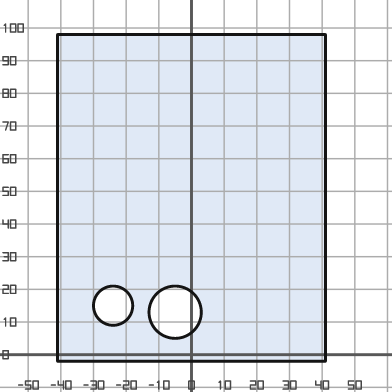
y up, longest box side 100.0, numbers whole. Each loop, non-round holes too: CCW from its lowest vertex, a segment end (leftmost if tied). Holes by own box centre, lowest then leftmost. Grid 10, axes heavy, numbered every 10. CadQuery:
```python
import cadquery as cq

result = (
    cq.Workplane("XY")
    .moveTo(-41.0, -2.0)
    .lineTo(41.0, -2.0)
    .lineTo(41.0, 98.0)
    .lineTo(-41.0, 98.0)
    .close()
    .moveTo(-5.0, 13.0)
    .circle(8.0)
    .moveTo(-24.0, 15.0)
    .circle(6.0)
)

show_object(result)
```